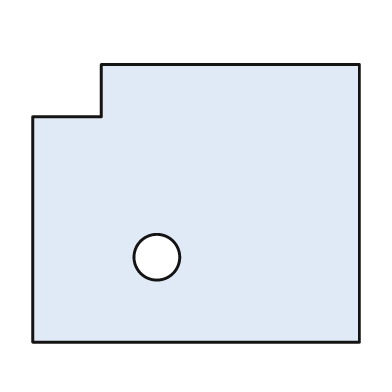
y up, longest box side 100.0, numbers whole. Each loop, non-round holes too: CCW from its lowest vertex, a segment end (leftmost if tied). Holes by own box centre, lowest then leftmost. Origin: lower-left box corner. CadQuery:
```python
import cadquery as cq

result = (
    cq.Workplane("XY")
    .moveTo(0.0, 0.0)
    .lineTo(100.0, 0.0)
    .lineTo(100.0, 85.0)
    .lineTo(21.0, 85.0)
    .lineTo(21.0, 69.0)
    .lineTo(0.0, 69.0)
    .close()
    .moveTo(38.0, 26.0)
    .circle(7.0)
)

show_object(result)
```